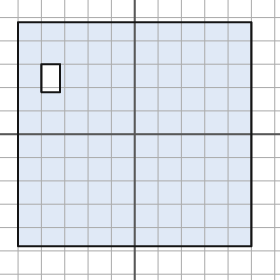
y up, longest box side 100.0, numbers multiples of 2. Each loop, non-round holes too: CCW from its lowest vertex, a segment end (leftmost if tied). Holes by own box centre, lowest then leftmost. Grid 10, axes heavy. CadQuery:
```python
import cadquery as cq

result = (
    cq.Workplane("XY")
    .moveTo(-50.0, -48.0)
    .lineTo(50.0, -48.0)
    .lineTo(50.0, 48.0)
    .lineTo(-50.0, 48.0)
    .close()
    .moveTo(-40.0, 18.0)
    .lineTo(-32.0, 18.0)
    .lineTo(-32.0, 30.0)
    .lineTo(-40.0, 30.0)
    .close()
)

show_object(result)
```